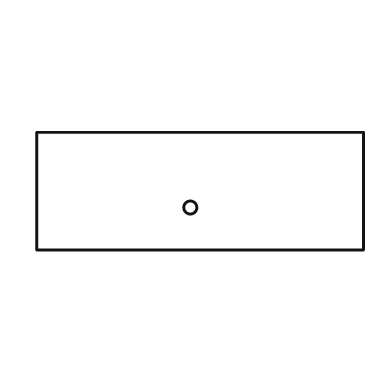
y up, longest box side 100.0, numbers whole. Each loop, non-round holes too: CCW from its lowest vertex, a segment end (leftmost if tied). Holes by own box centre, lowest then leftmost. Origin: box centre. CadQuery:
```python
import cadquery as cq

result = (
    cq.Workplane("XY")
    .moveTo(-50.0, -18.0)
    .lineTo(50.0, -18.0)
    .lineTo(50.0, 18.0)
    .lineTo(-50.0, 18.0)
    .close()
    .moveTo(-3.0, -5.0)
    .circle(2.0)
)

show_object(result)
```